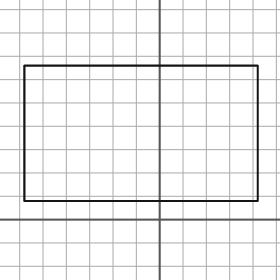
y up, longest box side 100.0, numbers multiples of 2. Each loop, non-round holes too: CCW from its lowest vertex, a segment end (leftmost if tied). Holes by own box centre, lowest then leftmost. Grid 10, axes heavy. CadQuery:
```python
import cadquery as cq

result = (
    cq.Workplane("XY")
    .moveTo(-58.0, 8.0)
    .lineTo(42.0, 8.0)
    .lineTo(42.0, 66.0)
    .lineTo(-58.0, 66.0)
    .close()
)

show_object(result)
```